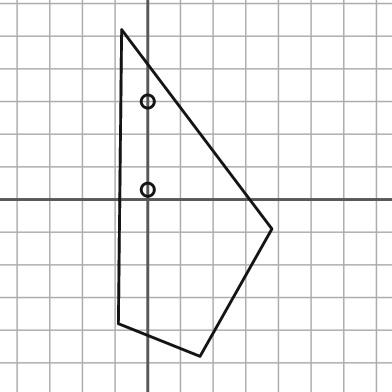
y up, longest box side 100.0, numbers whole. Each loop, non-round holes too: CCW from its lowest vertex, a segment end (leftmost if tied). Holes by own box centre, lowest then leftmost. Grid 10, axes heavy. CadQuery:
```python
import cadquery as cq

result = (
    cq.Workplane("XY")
    .moveTo(16.0, -48.0)
    .lineTo(38.0, -9.0)
    .lineTo(-8.0, 52.0)
    .lineTo(-9.0, -38.0)
    .close()
    .moveTo(0.0, 3.0)
    .circle(2.0)
    .moveTo(0.0, 30.0)
    .circle(2.0)
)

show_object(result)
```